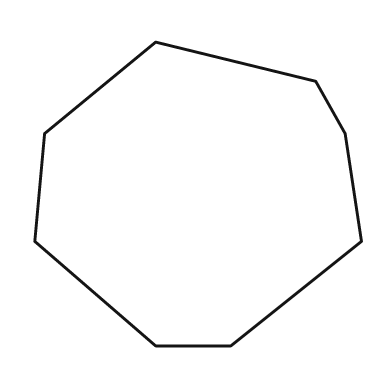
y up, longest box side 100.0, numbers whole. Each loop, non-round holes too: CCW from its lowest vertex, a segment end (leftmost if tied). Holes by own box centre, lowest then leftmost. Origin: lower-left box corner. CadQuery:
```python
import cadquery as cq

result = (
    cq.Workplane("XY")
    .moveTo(37.0, 0.0)
    .lineTo(60.0, 0.0)
    .lineTo(100.0, 32.0)
    .lineTo(95.0, 65.0)
    .lineTo(86.0, 81.0)
    .lineTo(37.0, 93.0)
    .lineTo(3.0, 65.0)
    .lineTo(0.0, 32.0)
    .close()
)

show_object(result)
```